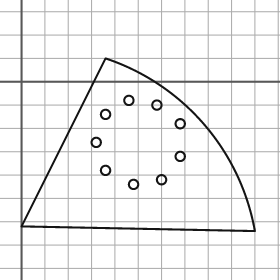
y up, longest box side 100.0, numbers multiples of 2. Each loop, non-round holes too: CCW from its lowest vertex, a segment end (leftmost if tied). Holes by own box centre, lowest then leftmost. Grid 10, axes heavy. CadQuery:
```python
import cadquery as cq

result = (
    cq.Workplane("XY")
    .moveTo(100.0, -64.0)
    .threePointArc((78.0, -18.0), (36.0, 10.0))
    .lineTo(0.0, -62.0)
    .close()
    .moveTo(48.0, -44.0)
    .circle(2.0)
    .moveTo(60.0, -42.0)
    .circle(2.0)
    .moveTo(36.0, -38.0)
    .circle(2.0)
    .moveTo(68.0, -32.0)
    .circle(2.0)
    .moveTo(32.0, -26.0)
    .circle(2.0)
    .moveTo(68.0, -18.0)
    .circle(2.0)
    .moveTo(36.0, -14.0)
    .circle(2.0)
    .moveTo(58.0, -10.0)
    .circle(2.0)
    .moveTo(46.0, -8.0)
    .circle(2.0)
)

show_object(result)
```